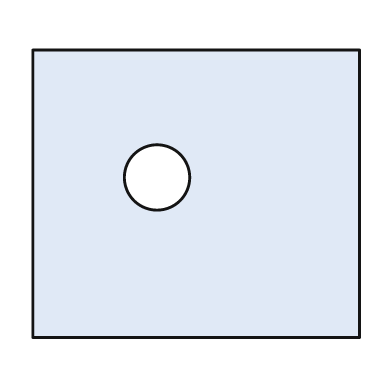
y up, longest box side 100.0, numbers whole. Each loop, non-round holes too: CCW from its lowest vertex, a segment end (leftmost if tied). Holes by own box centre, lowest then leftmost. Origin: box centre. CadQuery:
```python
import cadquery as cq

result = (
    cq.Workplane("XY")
    .moveTo(-50.0, -44.0)
    .lineTo(50.0, -44.0)
    .lineTo(50.0, 44.0)
    .lineTo(-50.0, 44.0)
    .close()
    .moveTo(-12.0, 5.0)
    .circle(10.0)
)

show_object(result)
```